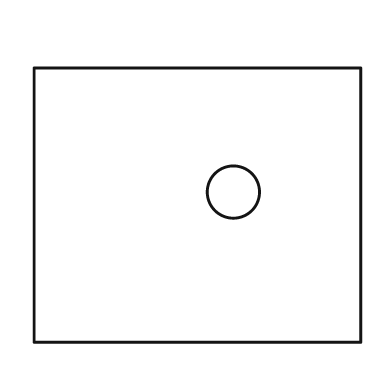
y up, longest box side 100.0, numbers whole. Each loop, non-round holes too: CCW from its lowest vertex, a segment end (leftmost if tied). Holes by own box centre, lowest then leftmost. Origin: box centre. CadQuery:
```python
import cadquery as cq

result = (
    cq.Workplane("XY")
    .moveTo(-50.0, -42.0)
    .lineTo(50.0, -42.0)
    .lineTo(50.0, 42.0)
    .lineTo(-50.0, 42.0)
    .close()
    .moveTo(11.0, 4.0)
    .circle(8.0)
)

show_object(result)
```